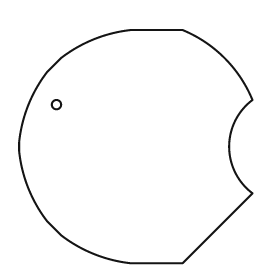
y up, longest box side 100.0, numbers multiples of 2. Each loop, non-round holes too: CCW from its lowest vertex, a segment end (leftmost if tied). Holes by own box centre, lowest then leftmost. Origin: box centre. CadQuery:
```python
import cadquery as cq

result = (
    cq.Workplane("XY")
    .moveTo(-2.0, -50.0)
    .lineTo(20.0, -50.0)
    .lineTo(50.0, -20.0)
    .threePointArc((40.0, 0.0), (50.0, 20.0))
    .threePointArc((38.0, 38.0), (20.0, 50.0))
    .lineTo(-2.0, 50.0)
    .threePointArc((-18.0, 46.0), (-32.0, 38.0))
    .lineTo(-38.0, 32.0)
    .threePointArc((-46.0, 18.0), (-50.0, 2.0))
    .lineTo(-50.0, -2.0)
    .threePointArc((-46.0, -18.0), (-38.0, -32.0))
    .lineTo(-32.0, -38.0)
    .threePointArc((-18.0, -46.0), (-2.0, -50.0))
    .close()
    .moveTo(-34.0, 18.0)
    .circle(2.0)
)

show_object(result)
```